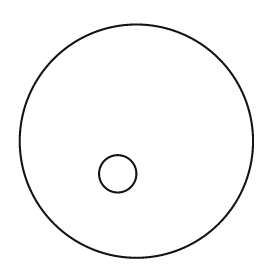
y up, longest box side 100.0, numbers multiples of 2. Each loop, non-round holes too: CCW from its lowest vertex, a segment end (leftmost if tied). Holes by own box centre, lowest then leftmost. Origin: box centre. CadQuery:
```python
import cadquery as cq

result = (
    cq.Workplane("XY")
    .moveTo(0.0, 0.0)
    .circle(50.0)
    .moveTo(-8.0, -14.0)
    .circle(8.0)
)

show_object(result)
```